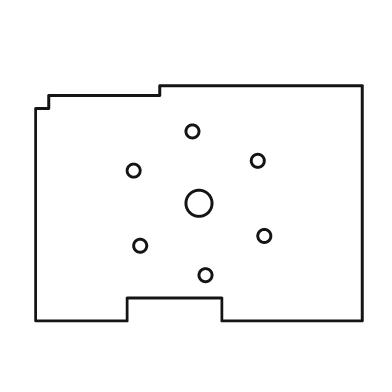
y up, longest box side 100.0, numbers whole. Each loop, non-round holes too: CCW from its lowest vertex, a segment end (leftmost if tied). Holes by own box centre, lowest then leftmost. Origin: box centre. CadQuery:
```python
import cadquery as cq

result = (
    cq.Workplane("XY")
    .moveTo(-50.0, -36.0)
    .lineTo(-22.0, -36.0)
    .lineTo(-22.0, -29.0)
    .lineTo(7.0, -29.0)
    .lineTo(7.0, -36.0)
    .lineTo(50.0, -36.0)
    .lineTo(50.0, 36.0)
    .lineTo(-12.0, 36.0)
    .lineTo(-12.0, 33.0)
    .lineTo(-46.0, 33.0)
    .lineTo(-46.0, 29.0)
    .lineTo(-50.0, 29.0)
    .close()
    .moveTo(2.0, -22.0)
    .circle(2.0)
    .moveTo(-18.0, -13.0)
    .circle(2.0)
    .moveTo(20.0, -10.0)
    .circle(2.0)
    .moveTo(0.0, 0.0)
    .circle(4.0)
    .moveTo(-20.0, 10.0)
    .circle(2.0)
    .moveTo(18.0, 13.0)
    .circle(2.0)
    .moveTo(-2.0, 22.0)
    .circle(2.0)
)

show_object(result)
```